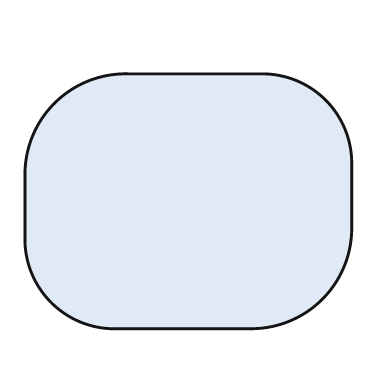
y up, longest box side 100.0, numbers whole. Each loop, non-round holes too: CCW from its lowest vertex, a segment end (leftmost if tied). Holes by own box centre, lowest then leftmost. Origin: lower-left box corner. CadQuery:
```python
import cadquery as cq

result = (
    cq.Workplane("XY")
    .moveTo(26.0, 0.0)
    .lineTo(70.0, 0.0)
    .threePointArc((91.0, 9.0), (100.0, 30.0))
    .lineTo(100.0, 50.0)
    .threePointArc((92.0, 70.0), (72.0, 78.0))
    .lineTo(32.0, 78.0)
    .threePointArc((9.0, 69.0), (0.0, 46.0))
    .lineTo(0.0, 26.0)
    .threePointArc((8.0, 8.0), (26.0, 0.0))
    .close()
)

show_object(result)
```